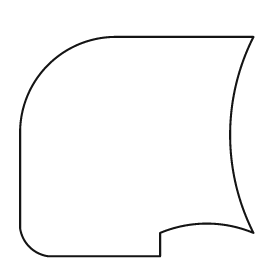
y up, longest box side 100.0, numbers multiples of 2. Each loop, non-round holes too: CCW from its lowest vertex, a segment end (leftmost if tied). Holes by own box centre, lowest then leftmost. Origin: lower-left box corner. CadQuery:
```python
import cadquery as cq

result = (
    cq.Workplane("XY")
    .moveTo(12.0, 0.0)
    .lineTo(60.0, 0.0)
    .lineTo(60.0, 10.0)
    .threePointArc((80.0, 14.0), (100.0, 10.0))
    .threePointArc((90.0, 52.0), (100.0, 94.0))
    .lineTo(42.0, 94.0)
    .threePointArc((12.0, 82.0), (0.0, 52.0))
    .lineTo(0.0, 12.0)
    .threePointArc((4.0, 4.0), (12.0, 0.0))
    .close()
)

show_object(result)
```